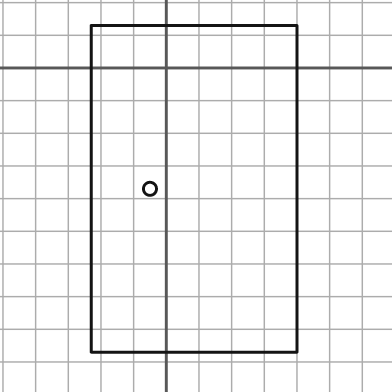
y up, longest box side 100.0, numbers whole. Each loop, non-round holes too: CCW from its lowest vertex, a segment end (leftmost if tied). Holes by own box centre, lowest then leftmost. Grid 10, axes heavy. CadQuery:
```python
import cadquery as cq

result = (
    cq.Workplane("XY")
    .moveTo(-23.0, -87.0)
    .lineTo(40.0, -87.0)
    .lineTo(40.0, 13.0)
    .lineTo(-23.0, 13.0)
    .close()
    .moveTo(-5.0, -37.0)
    .circle(2.0)
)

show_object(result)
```